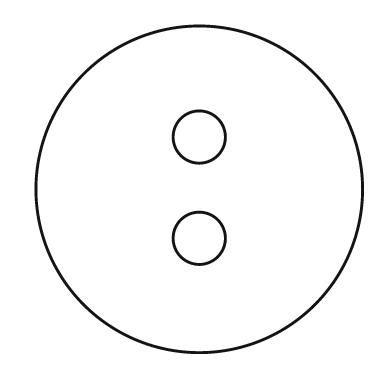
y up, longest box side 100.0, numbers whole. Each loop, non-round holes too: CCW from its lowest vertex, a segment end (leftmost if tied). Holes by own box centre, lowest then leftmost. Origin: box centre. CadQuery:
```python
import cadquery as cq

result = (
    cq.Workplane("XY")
    .moveTo(0.0, 0.0)
    .circle(50.0)
    .moveTo(0.0, -15.0)
    .circle(8.0)
    .moveTo(0.0, 16.0)
    .circle(8.0)
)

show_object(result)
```